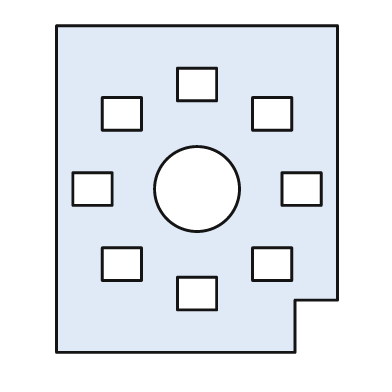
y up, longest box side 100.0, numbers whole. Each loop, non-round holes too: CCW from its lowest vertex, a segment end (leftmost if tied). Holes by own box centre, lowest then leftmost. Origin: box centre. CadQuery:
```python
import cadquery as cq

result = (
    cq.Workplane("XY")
    .moveTo(-43.0, -50.0)
    .lineTo(30.0, -50.0)
    .lineTo(30.0, -34.0)
    .lineTo(43.0, -34.0)
    .lineTo(43.0, 50.0)
    .lineTo(-43.0, 50.0)
    .close()
    .moveTo(-6.0, -37.0)
    .lineTo(6.0, -37.0)
    .lineTo(6.0, -27.0)
    .lineTo(-6.0, -27.0)
    .close()
    .moveTo(-29.0, -28.0)
    .lineTo(-17.0, -28.0)
    .lineTo(-17.0, -18.0)
    .lineTo(-29.0, -18.0)
    .close()
    .moveTo(17.0, -28.0)
    .lineTo(29.0, -28.0)
    .lineTo(29.0, -18.0)
    .lineTo(17.0, -18.0)
    .close()
    .moveTo(-38.0, -5.0)
    .lineTo(-26.0, -5.0)
    .lineTo(-26.0, 5.0)
    .lineTo(-38.0, 5.0)
    .close()
    .moveTo(0.0, 0.0)
    .circle(13.0)
    .moveTo(26.0, -5.0)
    .lineTo(38.0, -5.0)
    .lineTo(38.0, 5.0)
    .lineTo(26.0, 5.0)
    .close()
    .moveTo(-29.0, 18.0)
    .lineTo(-17.0, 18.0)
    .lineTo(-17.0, 28.0)
    .lineTo(-29.0, 28.0)
    .close()
    .moveTo(17.0, 18.0)
    .lineTo(29.0, 18.0)
    .lineTo(29.0, 28.0)
    .lineTo(17.0, 28.0)
    .close()
    .moveTo(-6.0, 27.0)
    .lineTo(6.0, 27.0)
    .lineTo(6.0, 37.0)
    .lineTo(-6.0, 37.0)
    .close()
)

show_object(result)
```